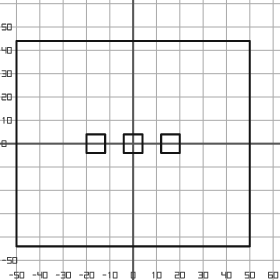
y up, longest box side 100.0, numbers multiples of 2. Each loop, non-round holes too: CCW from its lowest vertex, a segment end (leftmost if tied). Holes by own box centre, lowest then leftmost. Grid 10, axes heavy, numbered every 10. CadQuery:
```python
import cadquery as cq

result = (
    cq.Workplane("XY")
    .moveTo(-50.0, -44.0)
    .lineTo(50.0, -44.0)
    .lineTo(50.0, 44.0)
    .lineTo(-50.0, 44.0)
    .close()
    .moveTo(-20.0, -4.0)
    .lineTo(-12.0, -4.0)
    .lineTo(-12.0, 4.0)
    .lineTo(-20.0, 4.0)
    .close()
    .moveTo(-4.0, -4.0)
    .lineTo(4.0, -4.0)
    .lineTo(4.0, 4.0)
    .lineTo(-4.0, 4.0)
    .close()
    .moveTo(12.0, -4.0)
    .lineTo(20.0, -4.0)
    .lineTo(20.0, 4.0)
    .lineTo(12.0, 4.0)
    .close()
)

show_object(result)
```